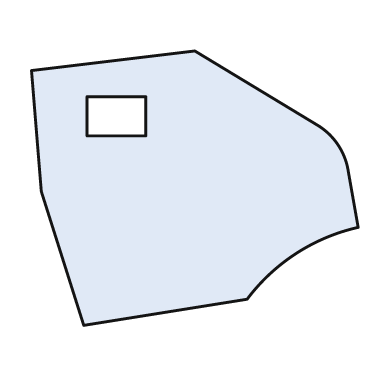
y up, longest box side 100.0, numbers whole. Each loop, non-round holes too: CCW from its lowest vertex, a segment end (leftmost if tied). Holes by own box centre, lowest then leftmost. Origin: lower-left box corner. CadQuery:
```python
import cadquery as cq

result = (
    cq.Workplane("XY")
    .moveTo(16.0, 0.0)
    .lineTo(66.0, 8.0)
    .threePointArc((81.0, 22.0), (100.0, 30.0))
    .lineTo(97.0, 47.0)
    .threePointArc((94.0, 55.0), (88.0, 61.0))
    .lineTo(50.0, 84.0)
    .lineTo(0.0, 78.0)
    .lineTo(3.0, 41.0)
    .close()
    .moveTo(17.0, 58.0)
    .lineTo(35.0, 58.0)
    .lineTo(35.0, 70.0)
    .lineTo(17.0, 70.0)
    .close()
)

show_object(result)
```